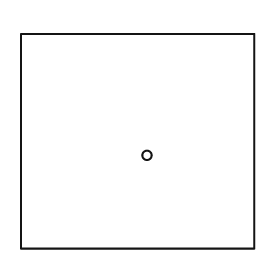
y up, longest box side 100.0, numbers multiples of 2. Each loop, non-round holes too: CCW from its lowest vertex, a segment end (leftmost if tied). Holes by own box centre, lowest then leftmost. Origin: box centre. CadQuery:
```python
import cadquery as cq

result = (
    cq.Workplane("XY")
    .moveTo(-50.0, -46.0)
    .lineTo(50.0, -46.0)
    .lineTo(50.0, 46.0)
    .lineTo(-50.0, 46.0)
    .close()
    .moveTo(4.0, -6.0)
    .circle(2.0)
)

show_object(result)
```